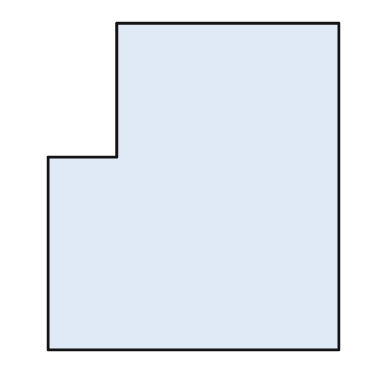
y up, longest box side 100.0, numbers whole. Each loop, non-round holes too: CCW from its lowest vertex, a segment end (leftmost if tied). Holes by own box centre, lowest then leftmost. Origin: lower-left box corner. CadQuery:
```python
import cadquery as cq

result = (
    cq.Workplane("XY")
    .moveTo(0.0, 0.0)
    .lineTo(89.0, 0.0)
    .lineTo(89.0, 100.0)
    .lineTo(21.0, 100.0)
    .lineTo(21.0, 59.0)
    .lineTo(0.0, 59.0)
    .close()
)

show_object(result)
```